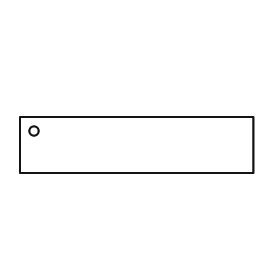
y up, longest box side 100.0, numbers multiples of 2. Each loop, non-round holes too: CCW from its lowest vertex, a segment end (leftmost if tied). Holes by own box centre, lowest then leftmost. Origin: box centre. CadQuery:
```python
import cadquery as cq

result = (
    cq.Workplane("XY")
    .moveTo(-50.0, -12.0)
    .lineTo(50.0, -12.0)
    .lineTo(50.0, 12.0)
    .lineTo(-50.0, 12.0)
    .close()
    .moveTo(-44.0, 6.0)
    .circle(2.0)
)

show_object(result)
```